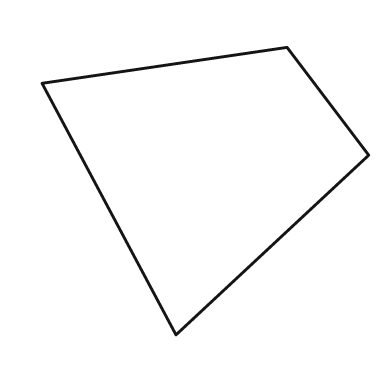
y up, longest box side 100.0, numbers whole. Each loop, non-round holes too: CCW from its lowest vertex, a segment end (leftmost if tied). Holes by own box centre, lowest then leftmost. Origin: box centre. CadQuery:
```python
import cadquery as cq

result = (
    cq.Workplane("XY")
    .moveTo(-9.0, -44.0)
    .lineTo(50.0, 11.0)
    .lineTo(25.0, 44.0)
    .lineTo(-50.0, 33.0)
    .close()
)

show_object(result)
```